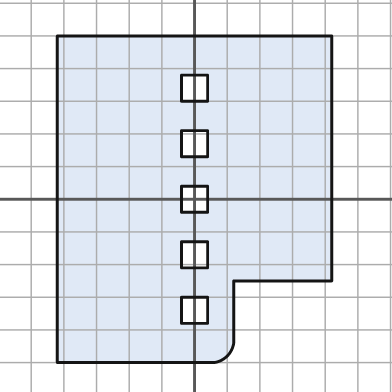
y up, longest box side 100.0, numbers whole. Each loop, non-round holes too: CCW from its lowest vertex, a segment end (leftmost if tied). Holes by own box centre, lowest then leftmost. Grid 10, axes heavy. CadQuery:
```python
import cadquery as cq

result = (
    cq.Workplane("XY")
    .moveTo(-42.0, -50.0)
    .lineTo(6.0, -50.0)
    .threePointArc((10.0, -48.0), (12.0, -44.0))
    .lineTo(12.0, -25.0)
    .lineTo(42.0, -25.0)
    .lineTo(42.0, 50.0)
    .lineTo(-42.0, 50.0)
    .close()
    .moveTo(-4.0, -38.0)
    .lineTo(4.0, -38.0)
    .lineTo(4.0, -30.0)
    .lineTo(-4.0, -30.0)
    .close()
    .moveTo(-4.0, -21.0)
    .lineTo(4.0, -21.0)
    .lineTo(4.0, -13.0)
    .lineTo(-4.0, -13.0)
    .close()
    .moveTo(-4.0, -4.0)
    .lineTo(4.0, -4.0)
    .lineTo(4.0, 4.0)
    .lineTo(-4.0, 4.0)
    .close()
    .moveTo(-4.0, 13.0)
    .lineTo(4.0, 13.0)
    .lineTo(4.0, 21.0)
    .lineTo(-4.0, 21.0)
    .close()
    .moveTo(-4.0, 30.0)
    .lineTo(4.0, 30.0)
    .lineTo(4.0, 38.0)
    .lineTo(-4.0, 38.0)
    .close()
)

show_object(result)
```